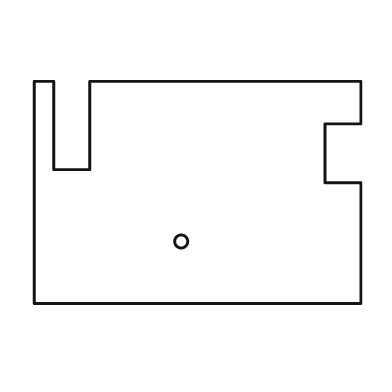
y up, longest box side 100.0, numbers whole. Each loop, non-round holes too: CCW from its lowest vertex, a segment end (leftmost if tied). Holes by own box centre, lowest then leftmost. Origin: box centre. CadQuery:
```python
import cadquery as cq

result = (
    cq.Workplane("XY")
    .moveTo(-50.0, -34.0)
    .lineTo(50.0, -34.0)
    .lineTo(50.0, 3.0)
    .lineTo(39.0, 3.0)
    .lineTo(39.0, 21.0)
    .lineTo(50.0, 21.0)
    .lineTo(50.0, 34.0)
    .lineTo(-33.0, 34.0)
    .lineTo(-33.0, 7.0)
    .lineTo(-44.0, 7.0)
    .lineTo(-44.0, 34.0)
    .lineTo(-50.0, 34.0)
    .close()
    .moveTo(-5.0, -15.0)
    .circle(2.0)
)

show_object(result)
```